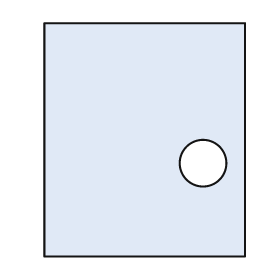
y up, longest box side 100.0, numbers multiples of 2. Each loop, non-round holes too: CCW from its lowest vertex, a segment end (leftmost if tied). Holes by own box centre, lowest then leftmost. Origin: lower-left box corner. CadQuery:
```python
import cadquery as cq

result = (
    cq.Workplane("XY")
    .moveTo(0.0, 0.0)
    .lineTo(86.0, 0.0)
    .lineTo(86.0, 100.0)
    .lineTo(0.0, 100.0)
    .close()
    .moveTo(68.0, 40.0)
    .circle(10.0)
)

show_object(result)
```